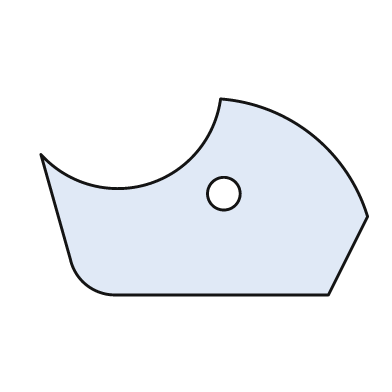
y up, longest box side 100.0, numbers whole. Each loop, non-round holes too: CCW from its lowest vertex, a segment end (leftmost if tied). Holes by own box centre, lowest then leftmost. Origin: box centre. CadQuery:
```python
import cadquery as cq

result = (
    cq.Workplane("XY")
    .moveTo(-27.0, -30.0)
    .lineTo(38.0, -30.0)
    .lineTo(50.0, -6.0)
    .threePointArc((33.0, 19.0), (5.0, 30.0))
    .threePointArc((-17.0, 4.0), (-50.0, 13.0))
    .lineTo(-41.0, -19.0)
    .threePointArc((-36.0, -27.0), (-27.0, -30.0))
    .close()
    .moveTo(6.0, 1.0)
    .circle(5.0)
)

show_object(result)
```